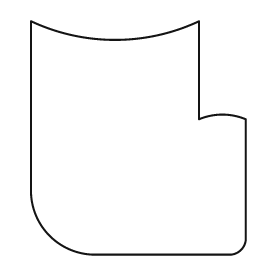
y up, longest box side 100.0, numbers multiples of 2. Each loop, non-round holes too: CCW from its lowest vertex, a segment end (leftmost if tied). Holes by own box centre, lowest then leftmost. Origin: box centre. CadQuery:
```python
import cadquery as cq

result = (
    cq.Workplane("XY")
    .moveTo(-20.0, -50.0)
    .lineTo(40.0, -50.0)
    .threePointArc((44.0, -48.0), (46.0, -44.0))
    .lineTo(46.0, 8.0)
    .threePointArc((36.0, 10.0), (26.0, 8.0))
    .lineTo(26.0, 50.0)
    .threePointArc((-10.0, 42.0), (-46.0, 50.0))
    .lineTo(-46.0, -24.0)
    .threePointArc((-38.0, -42.0), (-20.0, -50.0))
    .close()
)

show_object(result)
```